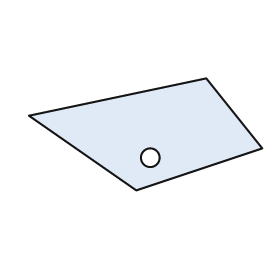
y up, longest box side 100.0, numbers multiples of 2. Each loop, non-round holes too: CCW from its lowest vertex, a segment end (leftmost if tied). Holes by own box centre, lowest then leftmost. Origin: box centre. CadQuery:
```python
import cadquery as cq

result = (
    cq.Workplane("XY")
    .moveTo(-4.0, -24.0)
    .lineTo(50.0, -6.0)
    .lineTo(26.0, 24.0)
    .lineTo(-50.0, 8.0)
    .close()
    .moveTo(2.0, -10.0)
    .circle(4.0)
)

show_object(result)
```